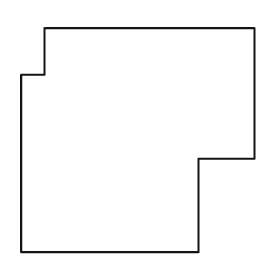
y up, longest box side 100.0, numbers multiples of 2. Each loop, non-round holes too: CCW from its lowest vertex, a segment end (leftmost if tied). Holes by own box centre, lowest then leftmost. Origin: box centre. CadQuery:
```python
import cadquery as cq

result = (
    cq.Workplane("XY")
    .moveTo(-50.0, -48.0)
    .lineTo(26.0, -48.0)
    .lineTo(26.0, -8.0)
    .lineTo(50.0, -8.0)
    .lineTo(50.0, 48.0)
    .lineTo(-40.0, 48.0)
    .lineTo(-40.0, 28.0)
    .lineTo(-50.0, 28.0)
    .close()
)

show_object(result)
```